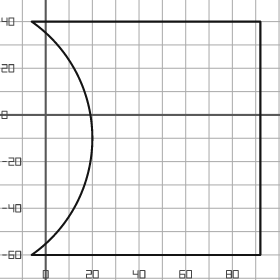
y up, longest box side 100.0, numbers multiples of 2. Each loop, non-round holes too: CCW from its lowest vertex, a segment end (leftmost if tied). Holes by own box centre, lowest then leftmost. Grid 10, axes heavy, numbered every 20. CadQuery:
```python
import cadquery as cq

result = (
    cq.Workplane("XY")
    .moveTo(-6.0, -60.0)
    .lineTo(92.0, -60.0)
    .lineTo(92.0, 40.0)
    .lineTo(-6.0, 40.0)
    .threePointArc((20.0, -10.0), (-6.0, -60.0))
    .close()
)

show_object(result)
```